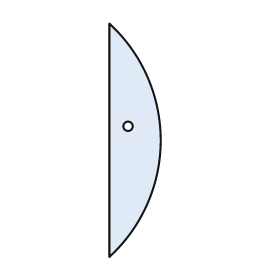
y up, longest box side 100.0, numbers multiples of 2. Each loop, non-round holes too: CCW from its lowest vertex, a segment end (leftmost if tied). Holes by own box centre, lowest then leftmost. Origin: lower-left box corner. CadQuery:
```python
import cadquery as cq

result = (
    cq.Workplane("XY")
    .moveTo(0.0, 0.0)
    .threePointArc((22.0, 50.0), (0.0, 100.0))
    .close()
    .moveTo(8.0, 56.0)
    .circle(2.0)
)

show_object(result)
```